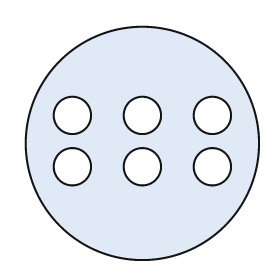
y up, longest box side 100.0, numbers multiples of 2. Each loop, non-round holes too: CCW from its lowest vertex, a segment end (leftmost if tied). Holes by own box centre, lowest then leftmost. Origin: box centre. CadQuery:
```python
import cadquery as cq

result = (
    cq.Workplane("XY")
    .moveTo(0.0, 0.0)
    .circle(50.0)
    .moveTo(-30.0, -10.0)
    .circle(8.0)
    .moveTo(0.0, -10.0)
    .circle(8.0)
    .moveTo(30.0, -10.0)
    .circle(8.0)
    .moveTo(-30.0, 12.0)
    .circle(8.0)
    .moveTo(0.0, 12.0)
    .circle(8.0)
    .moveTo(30.0, 12.0)
    .circle(8.0)
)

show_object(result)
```